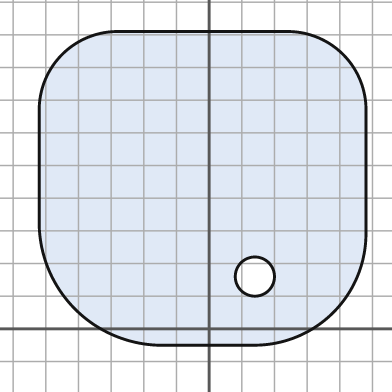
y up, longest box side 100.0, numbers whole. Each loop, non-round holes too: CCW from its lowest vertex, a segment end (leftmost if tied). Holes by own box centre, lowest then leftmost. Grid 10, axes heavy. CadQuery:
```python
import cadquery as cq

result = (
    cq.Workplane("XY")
    .moveTo(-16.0, -5.0)
    .lineTo(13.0, -5.0)
    .threePointArc((38.0, 5.0), (48.0, 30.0))
    .lineTo(48.0, 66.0)
    .threePointArc((41.0, 84.0), (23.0, 91.0))
    .lineTo(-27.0, 91.0)
    .threePointArc((-45.0, 84.0), (-52.0, 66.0))
    .lineTo(-52.0, 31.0)
    .threePointArc((-41.0, 6.0), (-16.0, -5.0))
    .close()
    .moveTo(14.0, 16.0)
    .circle(6.0)
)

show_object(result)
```